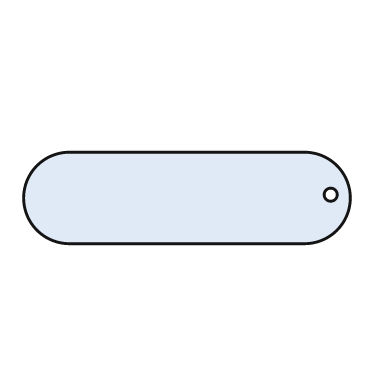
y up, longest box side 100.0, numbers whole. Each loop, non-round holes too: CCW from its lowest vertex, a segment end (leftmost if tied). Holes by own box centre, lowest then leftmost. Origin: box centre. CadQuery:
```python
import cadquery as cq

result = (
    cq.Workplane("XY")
    .moveTo(-36.0, -14.0)
    .lineTo(36.0, -14.0)
    .threePointArc((50.0, 0.0), (36.0, 14.0))
    .lineTo(-36.0, 14.0)
    .threePointArc((-50.0, 0.0), (-36.0, -14.0))
    .close()
    .moveTo(44.0, 1.0)
    .circle(2.0)
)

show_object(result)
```